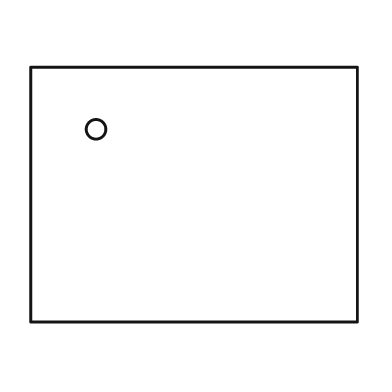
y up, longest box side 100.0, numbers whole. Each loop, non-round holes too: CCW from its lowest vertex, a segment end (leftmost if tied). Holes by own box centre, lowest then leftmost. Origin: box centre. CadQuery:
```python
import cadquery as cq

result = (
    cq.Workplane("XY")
    .moveTo(-50.0, -39.0)
    .lineTo(50.0, -39.0)
    .lineTo(50.0, 39.0)
    .lineTo(-50.0, 39.0)
    .close()
    .moveTo(-30.0, 20.0)
    .circle(3.0)
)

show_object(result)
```